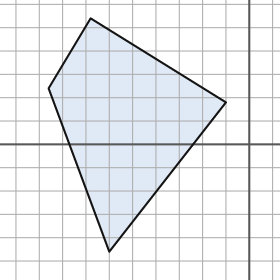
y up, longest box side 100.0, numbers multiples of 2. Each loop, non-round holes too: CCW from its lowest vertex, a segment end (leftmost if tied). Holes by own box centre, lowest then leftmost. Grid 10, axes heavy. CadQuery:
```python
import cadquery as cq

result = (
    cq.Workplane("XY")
    .moveTo(-60.0, -46.0)
    .lineTo(-10.0, 18.0)
    .lineTo(-68.0, 54.0)
    .lineTo(-86.0, 24.0)
    .close()
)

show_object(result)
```